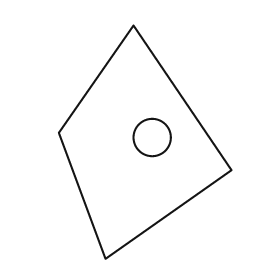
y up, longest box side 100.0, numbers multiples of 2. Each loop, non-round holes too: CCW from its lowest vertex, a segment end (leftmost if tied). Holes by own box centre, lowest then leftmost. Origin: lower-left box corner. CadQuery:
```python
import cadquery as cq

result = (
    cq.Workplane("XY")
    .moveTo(20.0, 0.0)
    .lineTo(74.0, 38.0)
    .lineTo(32.0, 100.0)
    .lineTo(0.0, 54.0)
    .close()
    .moveTo(40.0, 52.0)
    .circle(8.0)
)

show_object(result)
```